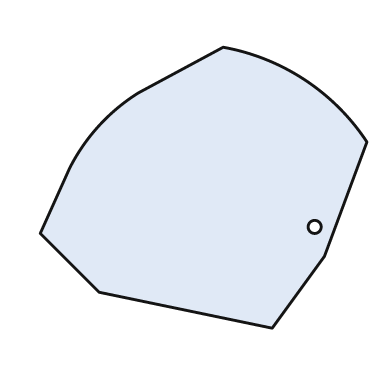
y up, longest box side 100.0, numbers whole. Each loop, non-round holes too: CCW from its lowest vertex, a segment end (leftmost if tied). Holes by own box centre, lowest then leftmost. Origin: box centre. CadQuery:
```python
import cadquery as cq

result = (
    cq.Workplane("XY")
    .moveTo(21.0, -43.0)
    .lineTo(37.0, -21.0)
    .lineTo(50.0, 14.0)
    .threePointArc((31.0, 33.0), (6.0, 43.0))
    .lineTo(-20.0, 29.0)
    .threePointArc((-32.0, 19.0), (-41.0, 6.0))
    .lineTo(-50.0, -14.0)
    .lineTo(-32.0, -32.0)
    .close()
    .moveTo(34.0, -12.0)
    .circle(2.0)
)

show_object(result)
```